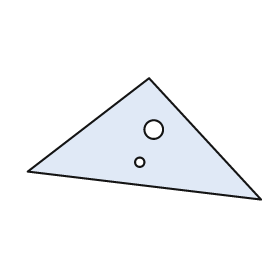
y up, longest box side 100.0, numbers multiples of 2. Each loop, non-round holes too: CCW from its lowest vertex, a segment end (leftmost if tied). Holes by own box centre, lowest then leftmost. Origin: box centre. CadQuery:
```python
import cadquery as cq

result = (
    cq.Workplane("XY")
    .moveTo(50.0, -26.0)
    .lineTo(2.0, 26.0)
    .lineTo(-50.0, -14.0)
    .close()
    .moveTo(-2.0, -10.0)
    .circle(2.0)
    .moveTo(4.0, 4.0)
    .circle(4.0)
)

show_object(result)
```